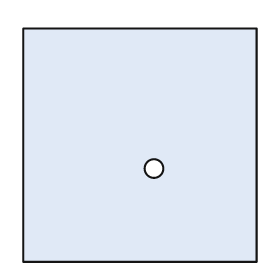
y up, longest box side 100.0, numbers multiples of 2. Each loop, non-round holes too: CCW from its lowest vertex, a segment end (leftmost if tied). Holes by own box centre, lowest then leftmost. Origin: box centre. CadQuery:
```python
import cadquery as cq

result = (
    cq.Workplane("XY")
    .moveTo(-50.0, -50.0)
    .lineTo(50.0, -50.0)
    .lineTo(50.0, 50.0)
    .lineTo(-50.0, 50.0)
    .close()
    .moveTo(6.0, -10.0)
    .circle(4.0)
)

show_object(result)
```